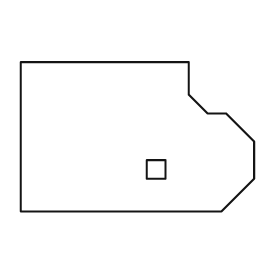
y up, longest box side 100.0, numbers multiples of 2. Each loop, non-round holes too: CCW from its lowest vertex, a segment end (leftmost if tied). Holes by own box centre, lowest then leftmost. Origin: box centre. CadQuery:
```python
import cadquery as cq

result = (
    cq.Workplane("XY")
    .moveTo(-50.0, -32.0)
    .lineTo(36.0, -32.0)
    .lineTo(50.0, -18.0)
    .lineTo(50.0, -2.0)
    .lineTo(38.0, 10.0)
    .lineTo(30.0, 10.0)
    .lineTo(22.0, 18.0)
    .lineTo(22.0, 32.0)
    .lineTo(-50.0, 32.0)
    .close()
    .moveTo(4.0, -18.0)
    .lineTo(12.0, -18.0)
    .lineTo(12.0, -10.0)
    .lineTo(4.0, -10.0)
    .close()
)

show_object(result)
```